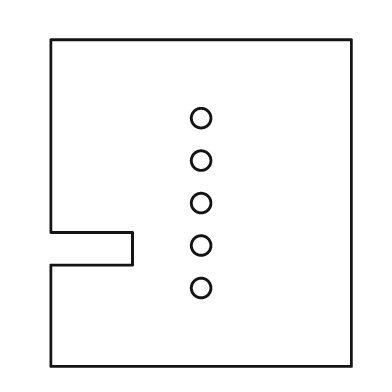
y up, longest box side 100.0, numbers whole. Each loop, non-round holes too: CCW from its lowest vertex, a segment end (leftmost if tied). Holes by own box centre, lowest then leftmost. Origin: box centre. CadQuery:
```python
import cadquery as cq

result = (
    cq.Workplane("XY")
    .moveTo(-46.0, -50.0)
    .lineTo(46.0, -50.0)
    .lineTo(46.0, 50.0)
    .lineTo(-46.0, 50.0)
    .lineTo(-46.0, -9.0)
    .lineTo(-21.0, -9.0)
    .lineTo(-21.0, -19.0)
    .lineTo(-46.0, -19.0)
    .close()
    .moveTo(0.0, -26.0)
    .circle(3.0)
    .moveTo(0.0, -13.0)
    .circle(3.0)
    .moveTo(0.0, 0.0)
    .circle(3.0)
    .moveTo(0.0, 13.0)
    .circle(3.0)
    .moveTo(0.0, 26.0)
    .circle(3.0)
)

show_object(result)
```